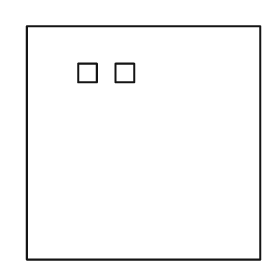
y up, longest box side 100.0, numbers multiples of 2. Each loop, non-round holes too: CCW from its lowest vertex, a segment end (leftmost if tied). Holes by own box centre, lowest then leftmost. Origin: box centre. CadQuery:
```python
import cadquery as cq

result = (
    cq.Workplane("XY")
    .moveTo(-50.0, -50.0)
    .lineTo(50.0, -50.0)
    .lineTo(50.0, 50.0)
    .lineTo(-50.0, 50.0)
    .close()
    .moveTo(-28.0, 26.0)
    .lineTo(-20.0, 26.0)
    .lineTo(-20.0, 34.0)
    .lineTo(-28.0, 34.0)
    .close()
    .moveTo(-12.0, 26.0)
    .lineTo(-4.0, 26.0)
    .lineTo(-4.0, 34.0)
    .lineTo(-12.0, 34.0)
    .close()
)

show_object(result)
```